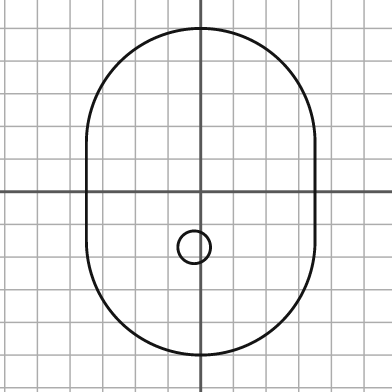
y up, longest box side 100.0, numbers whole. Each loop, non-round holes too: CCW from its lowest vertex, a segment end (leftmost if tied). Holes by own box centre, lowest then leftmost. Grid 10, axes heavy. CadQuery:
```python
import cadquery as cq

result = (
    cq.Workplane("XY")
    .moveTo(-35.0, -15.0)
    .threePointArc((0.0, -50.0), (35.0, -15.0))
    .lineTo(35.0, 15.0)
    .threePointArc((0.0, 50.0), (-35.0, 15.0))
    .close()
    .moveTo(-2.0, -17.0)
    .circle(5.0)
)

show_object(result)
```